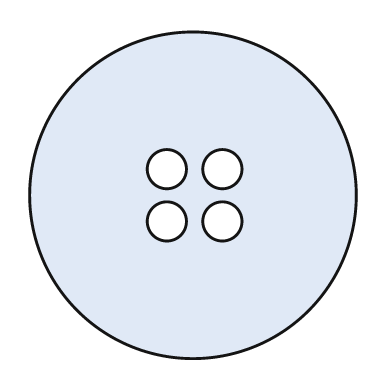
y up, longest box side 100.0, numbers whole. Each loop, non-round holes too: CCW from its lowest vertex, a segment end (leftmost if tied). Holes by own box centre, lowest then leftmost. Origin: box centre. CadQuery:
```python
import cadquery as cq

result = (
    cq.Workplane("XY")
    .moveTo(0.0, 0.0)
    .circle(50.0)
    .moveTo(-8.0, -8.0)
    .circle(6.0)
    .moveTo(9.0, -8.0)
    .circle(6.0)
    .moveTo(-8.0, 8.0)
    .circle(6.0)
    .moveTo(9.0, 8.0)
    .circle(6.0)
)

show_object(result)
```